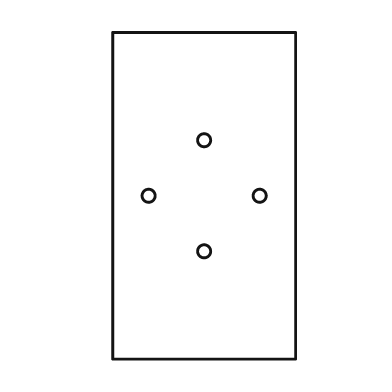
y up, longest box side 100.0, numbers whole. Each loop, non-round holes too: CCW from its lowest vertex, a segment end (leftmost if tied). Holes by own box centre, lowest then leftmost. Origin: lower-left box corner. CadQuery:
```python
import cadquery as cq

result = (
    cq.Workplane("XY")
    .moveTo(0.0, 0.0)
    .lineTo(56.0, 0.0)
    .lineTo(56.0, 100.0)
    .lineTo(0.0, 100.0)
    .close()
    .moveTo(28.0, 33.0)
    .circle(2.0)
    .moveTo(11.0, 50.0)
    .circle(2.0)
    .moveTo(45.0, 50.0)
    .circle(2.0)
    .moveTo(28.0, 67.0)
    .circle(2.0)
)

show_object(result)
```